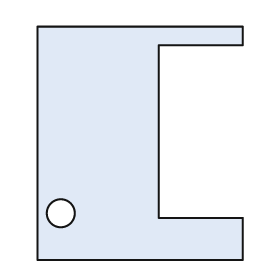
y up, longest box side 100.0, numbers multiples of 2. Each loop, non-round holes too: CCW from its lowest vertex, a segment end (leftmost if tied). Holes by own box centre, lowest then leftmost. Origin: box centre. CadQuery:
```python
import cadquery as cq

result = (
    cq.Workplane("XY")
    .moveTo(-44.0, -50.0)
    .lineTo(44.0, -50.0)
    .lineTo(44.0, -32.0)
    .lineTo(8.0, -32.0)
    .lineTo(8.0, 42.0)
    .lineTo(44.0, 42.0)
    .lineTo(44.0, 50.0)
    .lineTo(-44.0, 50.0)
    .close()
    .moveTo(-34.0, -30.0)
    .circle(6.0)
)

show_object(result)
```